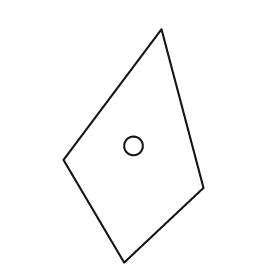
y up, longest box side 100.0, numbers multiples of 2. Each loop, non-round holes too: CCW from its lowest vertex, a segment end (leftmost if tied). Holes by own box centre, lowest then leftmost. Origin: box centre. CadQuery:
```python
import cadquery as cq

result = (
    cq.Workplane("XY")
    .moveTo(-4.0, -50.0)
    .lineTo(30.0, -18.0)
    .lineTo(12.0, 50.0)
    .lineTo(-30.0, -6.0)
    .close()
    .moveTo(0.0, 0.0)
    .circle(4.0)
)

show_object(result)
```